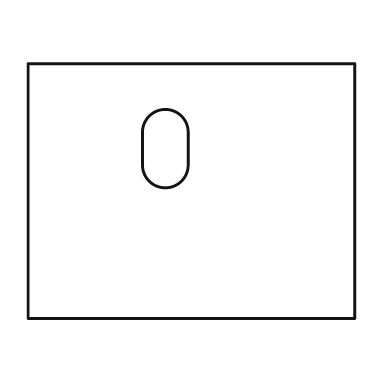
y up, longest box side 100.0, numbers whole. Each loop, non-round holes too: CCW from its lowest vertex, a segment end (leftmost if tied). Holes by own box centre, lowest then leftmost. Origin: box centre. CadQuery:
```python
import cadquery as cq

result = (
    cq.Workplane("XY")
    .moveTo(-50.0, -39.0)
    .lineTo(50.0, -39.0)
    .lineTo(50.0, 39.0)
    .lineTo(-50.0, 39.0)
    .close()
    .moveTo(-15.0, 8.0)
    .threePointArc((-8.0, 1.0), (-1.0, 8.0))
    .lineTo(-1.0, 18.0)
    .threePointArc((-8.0, 25.0), (-15.0, 18.0))
    .close()
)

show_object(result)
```